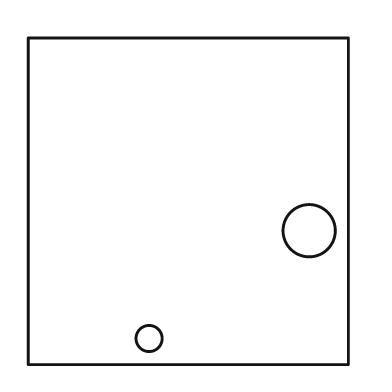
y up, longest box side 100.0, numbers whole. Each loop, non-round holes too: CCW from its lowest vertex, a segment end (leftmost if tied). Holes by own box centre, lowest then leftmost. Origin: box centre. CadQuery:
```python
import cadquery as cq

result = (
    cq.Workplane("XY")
    .moveTo(-49.0, -50.0)
    .lineTo(49.0, -50.0)
    .lineTo(49.0, 50.0)
    .lineTo(-49.0, 50.0)
    .close()
    .moveTo(-12.0, -42.0)
    .circle(4.0)
    .moveTo(37.0, -9.0)
    .circle(8.0)
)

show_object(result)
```